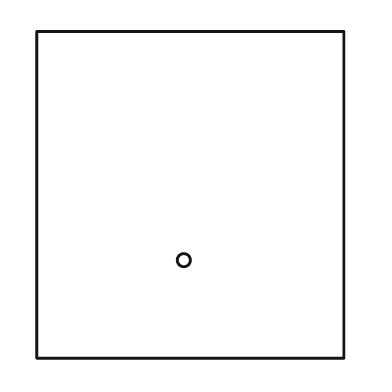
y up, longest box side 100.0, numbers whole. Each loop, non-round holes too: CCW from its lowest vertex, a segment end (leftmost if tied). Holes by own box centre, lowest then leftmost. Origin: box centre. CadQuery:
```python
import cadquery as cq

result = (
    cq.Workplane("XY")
    .moveTo(-47.0, -50.0)
    .lineTo(47.0, -50.0)
    .lineTo(47.0, 50.0)
    .lineTo(-47.0, 50.0)
    .close()
    .moveTo(-2.0, -20.0)
    .circle(2.0)
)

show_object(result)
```